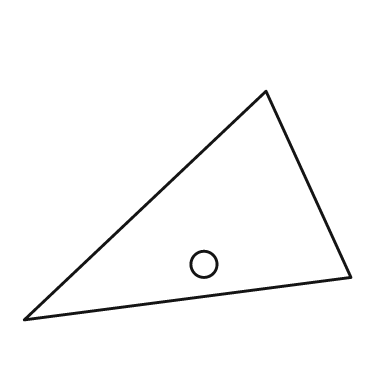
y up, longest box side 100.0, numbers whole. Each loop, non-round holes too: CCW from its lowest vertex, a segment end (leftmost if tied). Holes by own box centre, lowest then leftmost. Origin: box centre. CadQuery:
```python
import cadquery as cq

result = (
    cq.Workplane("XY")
    .moveTo(-50.0, -35.0)
    .lineTo(50.0, -22.0)
    .lineTo(24.0, 35.0)
    .close()
    .moveTo(5.0, -18.0)
    .circle(4.0)
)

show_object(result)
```